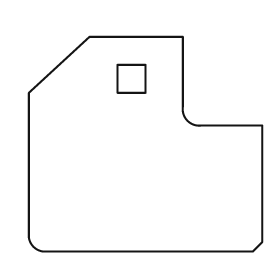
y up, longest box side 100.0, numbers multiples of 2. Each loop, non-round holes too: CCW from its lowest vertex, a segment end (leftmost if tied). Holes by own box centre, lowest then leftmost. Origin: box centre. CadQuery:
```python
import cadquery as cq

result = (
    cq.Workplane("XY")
    .moveTo(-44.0, -46.0)
    .lineTo(46.0, -46.0)
    .lineTo(50.0, -42.0)
    .lineTo(50.0, 8.0)
    .lineTo(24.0, 8.0)
    .threePointArc((18.0, 10.0), (16.0, 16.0))
    .lineTo(16.0, 46.0)
    .lineTo(-24.0, 46.0)
    .lineTo(-50.0, 22.0)
    .lineTo(-50.0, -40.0)
    .threePointArc((-48.0, -44.0), (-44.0, -46.0))
    .close()
    .moveTo(-12.0, 22.0)
    .lineTo(0.0, 22.0)
    .lineTo(0.0, 34.0)
    .lineTo(-12.0, 34.0)
    .close()
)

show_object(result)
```